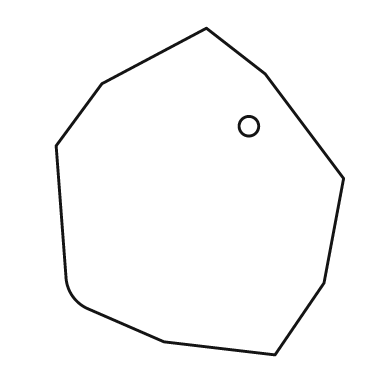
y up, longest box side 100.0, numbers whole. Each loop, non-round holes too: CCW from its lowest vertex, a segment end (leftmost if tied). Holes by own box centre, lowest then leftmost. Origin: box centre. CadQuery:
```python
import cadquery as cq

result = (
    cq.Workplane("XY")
    .moveTo(23.0, -50.0)
    .lineTo(38.0, -28.0)
    .lineTo(44.0, 4.0)
    .lineTo(20.0, 36.0)
    .lineTo(2.0, 50.0)
    .lineTo(-30.0, 33.0)
    .lineTo(-44.0, 14.0)
    .lineTo(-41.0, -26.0)
    .threePointArc((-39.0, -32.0), (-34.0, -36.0))
    .lineTo(-11.0, -46.0)
    .close()
    .moveTo(15.0, 20.0)
    .circle(3.0)
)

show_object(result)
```